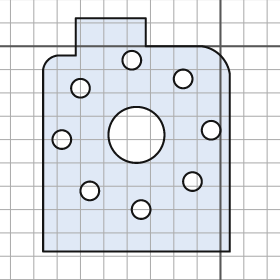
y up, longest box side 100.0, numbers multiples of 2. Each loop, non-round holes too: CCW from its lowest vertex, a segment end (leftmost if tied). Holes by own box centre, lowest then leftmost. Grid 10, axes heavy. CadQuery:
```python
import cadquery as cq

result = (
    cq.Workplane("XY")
    .moveTo(-76.0, -88.0)
    .lineTo(4.0, -88.0)
    .lineTo(4.0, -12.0)
    .threePointArc((0.0, -4.0), (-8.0, 0.0))
    .lineTo(-32.0, 0.0)
    .lineTo(-32.0, 12.0)
    .lineTo(-62.0, 12.0)
    .lineTo(-62.0, -4.0)
    .lineTo(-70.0, -4.0)
    .threePointArc((-74.0, -6.0), (-76.0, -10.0))
    .close()
    .moveTo(-34.0, -70.0)
    .circle(4.0)
    .moveTo(-56.0, -62.0)
    .circle(4.0)
    .moveTo(-12.0, -58.0)
    .circle(4.0)
    .moveTo(-68.0, -40.0)
    .circle(4.0)
    .moveTo(-36.0, -38.0)
    .circle(12.0)
    .moveTo(-4.0, -36.0)
    .circle(4.0)
    .moveTo(-60.0, -18.0)
    .circle(4.0)
    .moveTo(-16.0, -14.0)
    .circle(4.0)
    .moveTo(-38.0, -6.0)
    .circle(4.0)
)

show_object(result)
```